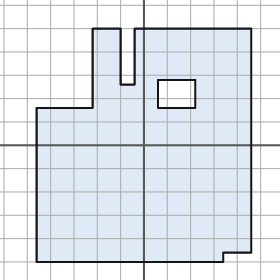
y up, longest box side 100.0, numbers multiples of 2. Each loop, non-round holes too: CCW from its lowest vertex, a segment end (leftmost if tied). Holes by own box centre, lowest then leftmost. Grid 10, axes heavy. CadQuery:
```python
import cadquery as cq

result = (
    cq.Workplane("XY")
    .moveTo(-46.0, -50.0)
    .lineTo(34.0, -50.0)
    .lineTo(34.0, -46.0)
    .lineTo(46.0, -46.0)
    .lineTo(46.0, 50.0)
    .lineTo(-4.0, 50.0)
    .lineTo(-4.0, 26.0)
    .lineTo(-10.0, 26.0)
    .lineTo(-10.0, 50.0)
    .lineTo(-22.0, 50.0)
    .lineTo(-22.0, 16.0)
    .lineTo(-46.0, 16.0)
    .close()
    .moveTo(6.0, 16.0)
    .lineTo(22.0, 16.0)
    .lineTo(22.0, 28.0)
    .lineTo(6.0, 28.0)
    .close()
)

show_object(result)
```